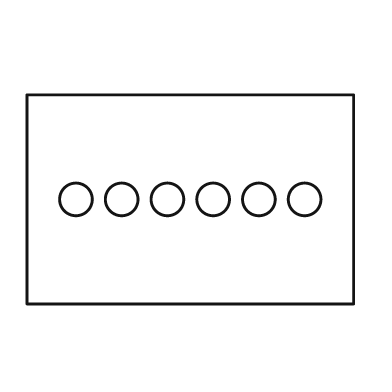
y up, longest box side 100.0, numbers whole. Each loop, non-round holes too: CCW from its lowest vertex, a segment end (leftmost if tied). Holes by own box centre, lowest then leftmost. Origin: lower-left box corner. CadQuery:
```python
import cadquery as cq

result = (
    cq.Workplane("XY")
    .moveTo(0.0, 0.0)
    .lineTo(100.0, 0.0)
    .lineTo(100.0, 64.0)
    .lineTo(0.0, 64.0)
    .close()
    .moveTo(15.0, 32.0)
    .circle(5.0)
    .moveTo(29.0, 32.0)
    .circle(5.0)
    .moveTo(43.0, 32.0)
    .circle(5.0)
    .moveTo(57.0, 32.0)
    .circle(5.0)
    .moveTo(71.0, 32.0)
    .circle(5.0)
    .moveTo(85.0, 32.0)
    .circle(5.0)
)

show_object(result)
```